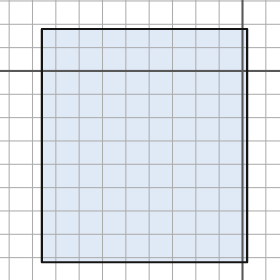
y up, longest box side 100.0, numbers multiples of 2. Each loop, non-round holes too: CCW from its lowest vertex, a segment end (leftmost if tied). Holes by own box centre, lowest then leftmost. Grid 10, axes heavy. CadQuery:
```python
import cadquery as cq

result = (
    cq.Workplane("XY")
    .moveTo(-86.0, -82.0)
    .lineTo(2.0, -82.0)
    .lineTo(2.0, 18.0)
    .lineTo(-86.0, 18.0)
    .close()
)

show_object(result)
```